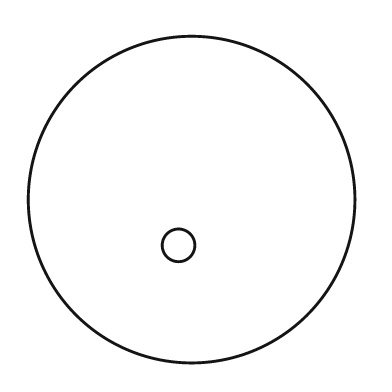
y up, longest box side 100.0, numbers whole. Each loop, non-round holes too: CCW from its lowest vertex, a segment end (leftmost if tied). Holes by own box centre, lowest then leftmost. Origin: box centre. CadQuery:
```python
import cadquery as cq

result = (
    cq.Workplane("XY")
    .moveTo(0.0, 0.0)
    .circle(50.0)
    .moveTo(-4.0, -14.0)
    .circle(5.0)
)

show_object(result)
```